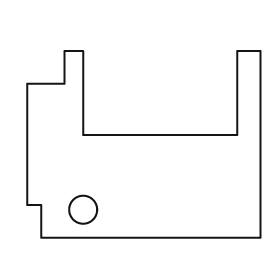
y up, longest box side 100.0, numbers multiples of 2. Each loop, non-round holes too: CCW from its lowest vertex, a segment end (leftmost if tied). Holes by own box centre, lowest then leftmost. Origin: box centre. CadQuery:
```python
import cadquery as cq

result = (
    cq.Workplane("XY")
    .moveTo(-44.0, -40.0)
    .lineTo(50.0, -40.0)
    .lineTo(50.0, 40.0)
    .lineTo(40.0, 40.0)
    .lineTo(40.0, 4.0)
    .lineTo(-26.0, 4.0)
    .lineTo(-26.0, 40.0)
    .lineTo(-34.0, 40.0)
    .lineTo(-34.0, 26.0)
    .lineTo(-50.0, 26.0)
    .lineTo(-50.0, -26.0)
    .lineTo(-44.0, -26.0)
    .close()
    .moveTo(-26.0, -28.0)
    .circle(6.0)
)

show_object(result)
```